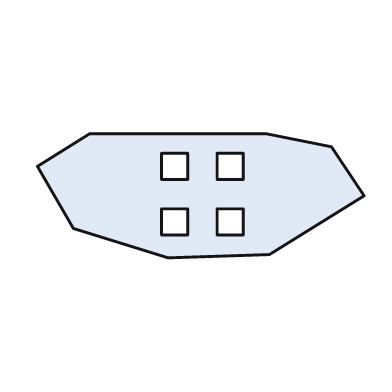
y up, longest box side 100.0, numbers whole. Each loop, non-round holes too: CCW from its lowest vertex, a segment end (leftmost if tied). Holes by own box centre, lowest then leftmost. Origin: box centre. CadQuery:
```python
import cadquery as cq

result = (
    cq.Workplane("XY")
    .moveTo(-10.0, -19.0)
    .lineTo(21.0, -18.0)
    .lineTo(50.0, 0.0)
    .lineTo(40.0, 15.0)
    .lineTo(20.0, 19.0)
    .lineTo(-34.0, 19.0)
    .lineTo(-50.0, 9.0)
    .lineTo(-39.0, -10.0)
    .close()
    .moveTo(-12.0, -12.0)
    .lineTo(-4.0, -12.0)
    .lineTo(-4.0, -4.0)
    .lineTo(-12.0, -4.0)
    .close()
    .moveTo(5.0, -12.0)
    .lineTo(13.0, -12.0)
    .lineTo(13.0, -4.0)
    .lineTo(5.0, -4.0)
    .close()
    .moveTo(-12.0, 5.0)
    .lineTo(-4.0, 5.0)
    .lineTo(-4.0, 13.0)
    .lineTo(-12.0, 13.0)
    .close()
    .moveTo(5.0, 5.0)
    .lineTo(13.0, 5.0)
    .lineTo(13.0, 13.0)
    .lineTo(5.0, 13.0)
    .close()
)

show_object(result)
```